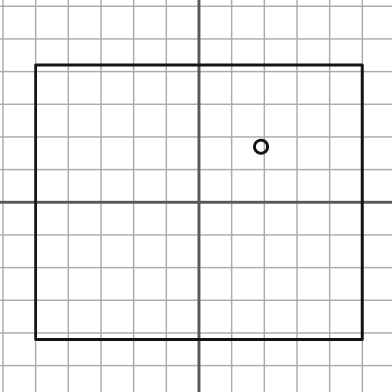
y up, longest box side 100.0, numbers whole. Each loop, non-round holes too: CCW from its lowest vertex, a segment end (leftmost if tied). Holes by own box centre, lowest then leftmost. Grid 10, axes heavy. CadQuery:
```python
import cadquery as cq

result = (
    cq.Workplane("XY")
    .moveTo(-50.0, -42.0)
    .lineTo(50.0, -42.0)
    .lineTo(50.0, 42.0)
    .lineTo(-50.0, 42.0)
    .close()
    .moveTo(19.0, 17.0)
    .circle(2.0)
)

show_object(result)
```